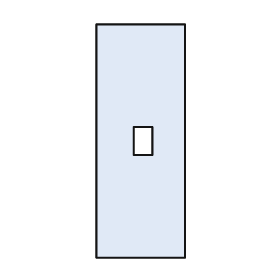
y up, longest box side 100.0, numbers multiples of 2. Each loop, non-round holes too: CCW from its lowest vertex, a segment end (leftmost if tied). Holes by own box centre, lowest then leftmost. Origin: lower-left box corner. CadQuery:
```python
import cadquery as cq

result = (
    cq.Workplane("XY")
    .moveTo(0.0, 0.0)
    .lineTo(38.0, 0.0)
    .lineTo(38.0, 100.0)
    .lineTo(0.0, 100.0)
    .close()
    .moveTo(16.0, 44.0)
    .lineTo(24.0, 44.0)
    .lineTo(24.0, 56.0)
    .lineTo(16.0, 56.0)
    .close()
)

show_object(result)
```